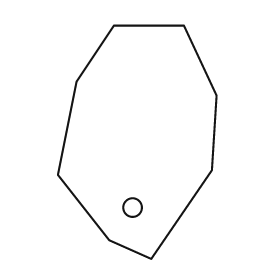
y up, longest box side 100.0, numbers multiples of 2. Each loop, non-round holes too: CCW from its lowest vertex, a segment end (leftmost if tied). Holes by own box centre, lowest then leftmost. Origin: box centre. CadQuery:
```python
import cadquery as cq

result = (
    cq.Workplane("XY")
    .moveTo(6.0, -50.0)
    .lineTo(32.0, -12.0)
    .lineTo(34.0, 20.0)
    .lineTo(20.0, 50.0)
    .lineTo(-10.0, 50.0)
    .lineTo(-26.0, 26.0)
    .lineTo(-34.0, -14.0)
    .lineTo(-12.0, -42.0)
    .close()
    .moveTo(-2.0, -28.0)
    .circle(4.0)
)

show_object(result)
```